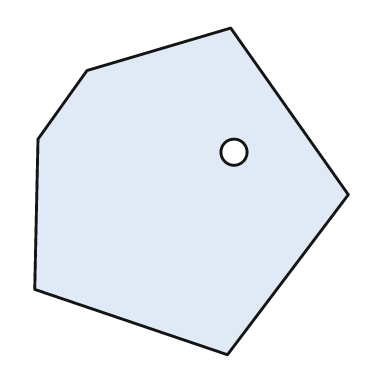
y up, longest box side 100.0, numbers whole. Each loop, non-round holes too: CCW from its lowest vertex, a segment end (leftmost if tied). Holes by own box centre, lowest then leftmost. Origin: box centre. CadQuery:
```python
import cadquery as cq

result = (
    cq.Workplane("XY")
    .moveTo(11.0, -50.0)
    .lineTo(48.0, -1.0)
    .lineTo(12.0, 50.0)
    .lineTo(-32.0, 37.0)
    .lineTo(-47.0, 16.0)
    .lineTo(-48.0, -30.0)
    .close()
    .moveTo(13.0, 12.0)
    .circle(4.0)
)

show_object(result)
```